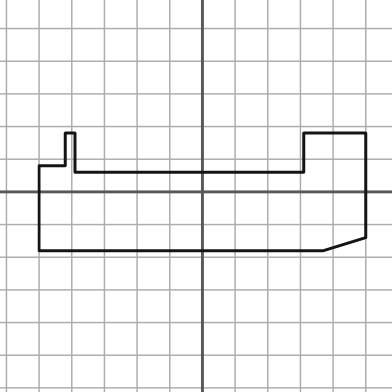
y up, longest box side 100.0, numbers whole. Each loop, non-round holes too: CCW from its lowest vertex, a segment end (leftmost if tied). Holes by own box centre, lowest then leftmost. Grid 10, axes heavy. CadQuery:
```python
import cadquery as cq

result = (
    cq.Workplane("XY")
    .moveTo(-50.0, -18.0)
    .lineTo(37.0, -18.0)
    .lineTo(50.0, -14.0)
    .lineTo(50.0, 18.0)
    .lineTo(31.0, 18.0)
    .lineTo(31.0, 6.0)
    .lineTo(-39.0, 6.0)
    .lineTo(-39.0, 18.0)
    .lineTo(-42.0, 18.0)
    .lineTo(-42.0, 8.0)
    .lineTo(-50.0, 8.0)
    .close()
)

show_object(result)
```